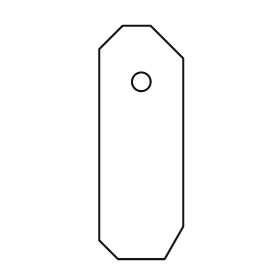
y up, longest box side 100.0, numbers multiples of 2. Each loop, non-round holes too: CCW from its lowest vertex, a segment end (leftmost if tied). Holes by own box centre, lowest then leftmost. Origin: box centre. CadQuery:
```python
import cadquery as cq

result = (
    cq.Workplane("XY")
    .moveTo(-10.0, -50.0)
    .lineTo(10.0, -50.0)
    .lineTo(18.0, -36.0)
    .lineTo(18.0, 36.0)
    .lineTo(4.0, 50.0)
    .lineTo(-8.0, 50.0)
    .lineTo(-18.0, 40.0)
    .lineTo(-18.0, -42.0)
    .close()
    .moveTo(0.0, 26.0)
    .circle(4.0)
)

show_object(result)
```